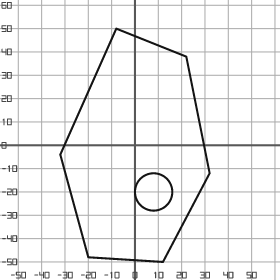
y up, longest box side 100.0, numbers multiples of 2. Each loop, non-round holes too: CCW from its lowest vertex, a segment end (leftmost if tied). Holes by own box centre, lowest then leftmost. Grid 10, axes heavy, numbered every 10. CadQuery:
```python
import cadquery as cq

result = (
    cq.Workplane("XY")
    .moveTo(12.0, -50.0)
    .lineTo(32.0, -12.0)
    .lineTo(22.0, 38.0)
    .lineTo(-8.0, 50.0)
    .lineTo(-32.0, -4.0)
    .lineTo(-20.0, -48.0)
    .close()
    .moveTo(8.0, -20.0)
    .circle(8.0)
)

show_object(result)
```